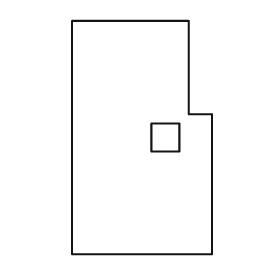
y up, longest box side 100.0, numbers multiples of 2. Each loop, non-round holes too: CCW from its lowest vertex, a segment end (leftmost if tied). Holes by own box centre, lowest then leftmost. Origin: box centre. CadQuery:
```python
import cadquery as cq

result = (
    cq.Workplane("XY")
    .moveTo(-30.0, -50.0)
    .lineTo(30.0, -50.0)
    .lineTo(30.0, 10.0)
    .lineTo(20.0, 10.0)
    .lineTo(20.0, 50.0)
    .lineTo(-30.0, 50.0)
    .close()
    .moveTo(4.0, -6.0)
    .lineTo(16.0, -6.0)
    .lineTo(16.0, 6.0)
    .lineTo(4.0, 6.0)
    .close()
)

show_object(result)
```